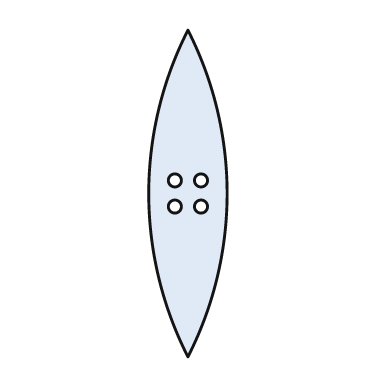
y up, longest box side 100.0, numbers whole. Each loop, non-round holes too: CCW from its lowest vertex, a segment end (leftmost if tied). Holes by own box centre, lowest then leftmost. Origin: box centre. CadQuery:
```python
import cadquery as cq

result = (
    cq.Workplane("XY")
    .moveTo(0.0, -50.0)
    .threePointArc((12.0, 0.0), (0.0, 50.0))
    .threePointArc((-12.0, 0.0), (0.0, -50.0))
    .close()
    .moveTo(-4.0, -4.0)
    .circle(2.0)
    .moveTo(4.0, -4.0)
    .circle(2.0)
    .moveTo(-4.0, 4.0)
    .circle(2.0)
    .moveTo(4.0, 4.0)
    .circle(2.0)
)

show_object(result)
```